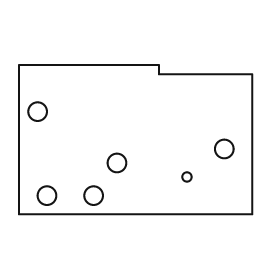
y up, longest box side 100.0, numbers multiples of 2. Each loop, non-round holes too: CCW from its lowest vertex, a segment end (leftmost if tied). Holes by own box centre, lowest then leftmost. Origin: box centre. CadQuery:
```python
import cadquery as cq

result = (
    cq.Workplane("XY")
    .moveTo(-50.0, -32.0)
    .lineTo(50.0, -32.0)
    .lineTo(50.0, 28.0)
    .lineTo(10.0, 28.0)
    .lineTo(10.0, 32.0)
    .lineTo(-50.0, 32.0)
    .close()
    .moveTo(-38.0, -24.0)
    .circle(4.0)
    .moveTo(-18.0, -24.0)
    .circle(4.0)
    .moveTo(22.0, -16.0)
    .circle(2.0)
    .moveTo(-8.0, -10.0)
    .circle(4.0)
    .moveTo(38.0, -4.0)
    .circle(4.0)
    .moveTo(-42.0, 12.0)
    .circle(4.0)
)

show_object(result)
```